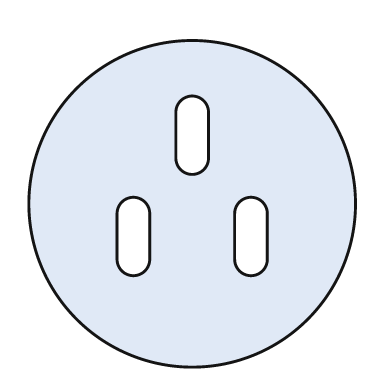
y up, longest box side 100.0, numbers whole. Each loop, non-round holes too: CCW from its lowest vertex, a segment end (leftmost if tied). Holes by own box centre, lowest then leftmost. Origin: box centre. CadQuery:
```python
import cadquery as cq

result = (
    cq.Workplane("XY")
    .moveTo(0.0, 0.0)
    .circle(50.0)
    .moveTo(-23.0, -17.0)
    .threePointArc((-18.0, -22.0), (-13.0, -17.0))
    .lineTo(-13.0, -3.0)
    .threePointArc((-18.0, 2.0), (-23.0, -3.0))
    .close()
    .moveTo(13.0, -17.0)
    .threePointArc((18.0, -22.0), (23.0, -17.0))
    .lineTo(23.0, -3.0)
    .threePointArc((18.0, 2.0), (13.0, -3.0))
    .close()
    .moveTo(-5.0, 14.0)
    .threePointArc((0.0, 9.0), (5.0, 14.0))
    .lineTo(5.0, 28.0)
    .threePointArc((0.0, 33.0), (-5.0, 28.0))
    .close()
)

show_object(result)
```